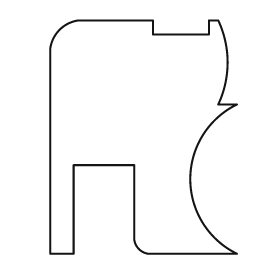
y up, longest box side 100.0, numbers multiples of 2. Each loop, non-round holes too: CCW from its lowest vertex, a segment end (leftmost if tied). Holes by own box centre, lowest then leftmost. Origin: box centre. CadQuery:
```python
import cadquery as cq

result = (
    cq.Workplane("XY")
    .moveTo(-40.0, -50.0)
    .lineTo(-30.0, -50.0)
    .lineTo(-30.0, -12.0)
    .lineTo(-4.0, -12.0)
    .lineTo(-4.0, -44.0)
    .threePointArc((-2.0, -48.0), (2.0, -50.0))
    .lineTo(40.0, -50.0)
    .threePointArc((20.0, -18.0), (40.0, 14.0))
    .lineTo(32.0, 14.0)
    .threePointArc((36.0, 32.0), (32.0, 50.0))
    .lineTo(28.0, 50.0)
    .lineTo(28.0, 44.0)
    .lineTo(4.0, 44.0)
    .lineTo(4.0, 50.0)
    .lineTo(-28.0, 50.0)
    .threePointArc((-36.0, 46.0), (-40.0, 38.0))
    .close()
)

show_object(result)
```